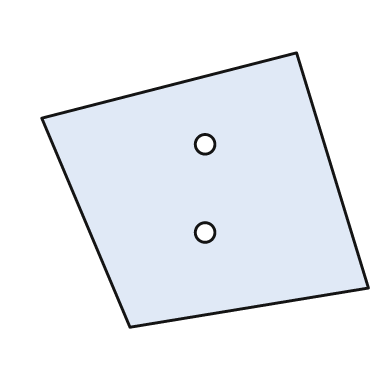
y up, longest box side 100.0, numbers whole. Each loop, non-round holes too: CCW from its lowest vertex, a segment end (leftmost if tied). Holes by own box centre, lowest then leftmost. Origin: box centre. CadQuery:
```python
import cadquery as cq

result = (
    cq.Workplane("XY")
    .moveTo(-23.0, -42.0)
    .lineTo(50.0, -30.0)
    .lineTo(28.0, 42.0)
    .lineTo(-50.0, 22.0)
    .close()
    .moveTo(0.0, -13.0)
    .circle(3.0)
    .moveTo(0.0, 14.0)
    .circle(3.0)
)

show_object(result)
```